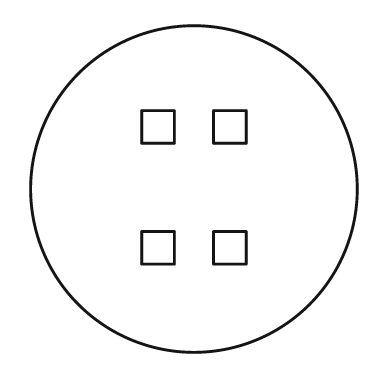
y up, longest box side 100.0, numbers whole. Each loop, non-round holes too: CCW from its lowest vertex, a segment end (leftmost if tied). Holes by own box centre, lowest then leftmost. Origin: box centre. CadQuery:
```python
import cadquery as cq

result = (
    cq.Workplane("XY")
    .moveTo(0.0, 0.0)
    .circle(50.0)
    .moveTo(-16.0, -23.0)
    .lineTo(-6.0, -23.0)
    .lineTo(-6.0, -13.0)
    .lineTo(-16.0, -13.0)
    .close()
    .moveTo(6.0, -23.0)
    .lineTo(16.0, -23.0)
    .lineTo(16.0, -13.0)
    .lineTo(6.0, -13.0)
    .close()
    .moveTo(-16.0, 14.0)
    .lineTo(-6.0, 14.0)
    .lineTo(-6.0, 24.0)
    .lineTo(-16.0, 24.0)
    .close()
    .moveTo(6.0, 14.0)
    .lineTo(16.0, 14.0)
    .lineTo(16.0, 24.0)
    .lineTo(6.0, 24.0)
    .close()
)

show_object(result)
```